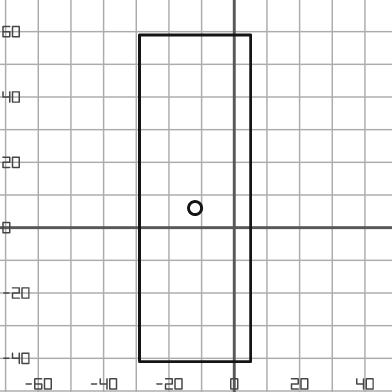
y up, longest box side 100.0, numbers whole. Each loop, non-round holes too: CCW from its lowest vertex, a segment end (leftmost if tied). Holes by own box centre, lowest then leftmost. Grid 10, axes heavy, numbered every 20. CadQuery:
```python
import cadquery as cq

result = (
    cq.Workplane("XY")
    .moveTo(-29.0, -41.0)
    .lineTo(5.0, -41.0)
    .lineTo(5.0, 59.0)
    .lineTo(-29.0, 59.0)
    .close()
    .moveTo(-12.0, 6.0)
    .circle(2.0)
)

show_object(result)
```